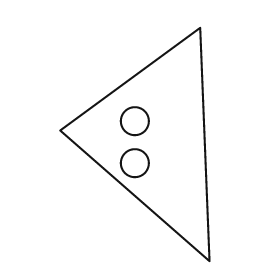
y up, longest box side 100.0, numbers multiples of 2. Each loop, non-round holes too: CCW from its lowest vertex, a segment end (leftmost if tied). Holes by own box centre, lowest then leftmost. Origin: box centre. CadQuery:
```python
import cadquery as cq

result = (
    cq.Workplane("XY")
    .moveTo(32.0, -50.0)
    .lineTo(28.0, 50.0)
    .lineTo(-32.0, 6.0)
    .close()
    .moveTo(0.0, -8.0)
    .circle(6.0)
    .moveTo(0.0, 10.0)
    .circle(6.0)
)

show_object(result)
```